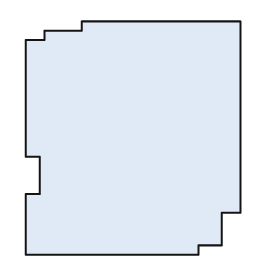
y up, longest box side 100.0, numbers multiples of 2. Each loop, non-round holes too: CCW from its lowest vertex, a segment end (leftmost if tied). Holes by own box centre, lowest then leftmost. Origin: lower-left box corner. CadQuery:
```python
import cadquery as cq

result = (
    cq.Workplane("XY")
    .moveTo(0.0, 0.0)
    .lineTo(74.0, 0.0)
    .lineTo(74.0, 4.0)
    .lineTo(84.0, 4.0)
    .lineTo(84.0, 18.0)
    .lineTo(92.0, 18.0)
    .lineTo(92.0, 100.0)
    .lineTo(24.0, 100.0)
    .lineTo(24.0, 96.0)
    .lineTo(8.0, 96.0)
    .lineTo(8.0, 92.0)
    .lineTo(0.0, 92.0)
    .lineTo(0.0, 42.0)
    .lineTo(6.0, 42.0)
    .lineTo(6.0, 26.0)
    .lineTo(0.0, 26.0)
    .close()
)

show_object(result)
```